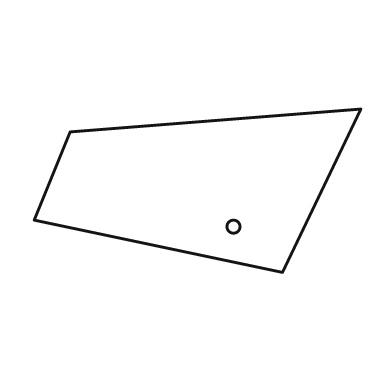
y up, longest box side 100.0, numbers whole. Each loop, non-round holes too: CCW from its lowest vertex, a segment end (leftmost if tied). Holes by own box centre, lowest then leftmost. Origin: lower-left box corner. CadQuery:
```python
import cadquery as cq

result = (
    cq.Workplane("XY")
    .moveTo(76.0, 0.0)
    .lineTo(100.0, 50.0)
    .lineTo(11.0, 43.0)
    .lineTo(0.0, 16.0)
    .close()
    .moveTo(61.0, 14.0)
    .circle(2.0)
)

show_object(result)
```